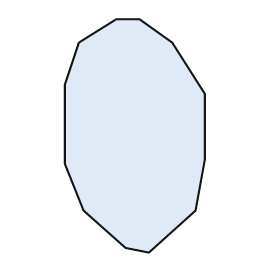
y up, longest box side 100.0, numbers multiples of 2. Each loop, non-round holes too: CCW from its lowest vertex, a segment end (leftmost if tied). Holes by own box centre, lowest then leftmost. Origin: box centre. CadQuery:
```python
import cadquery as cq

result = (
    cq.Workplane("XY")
    .moveTo(6.0, -50.0)
    .lineTo(26.0, -32.0)
    .lineTo(30.0, -10.0)
    .lineTo(30.0, 18.0)
    .lineTo(16.0, 40.0)
    .lineTo(2.0, 50.0)
    .lineTo(-8.0, 50.0)
    .lineTo(-24.0, 40.0)
    .lineTo(-30.0, 22.0)
    .lineTo(-30.0, -12.0)
    .lineTo(-22.0, -32.0)
    .lineTo(-4.0, -48.0)
    .close()
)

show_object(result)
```